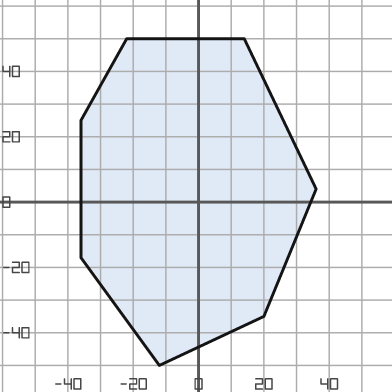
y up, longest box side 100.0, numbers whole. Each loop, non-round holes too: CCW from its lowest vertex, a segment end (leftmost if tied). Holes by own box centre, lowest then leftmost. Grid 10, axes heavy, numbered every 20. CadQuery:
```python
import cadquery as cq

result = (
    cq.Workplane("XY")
    .moveTo(-12.0, -50.0)
    .lineTo(20.0, -35.0)
    .lineTo(36.0, 4.0)
    .lineTo(14.0, 50.0)
    .lineTo(-22.0, 50.0)
    .lineTo(-36.0, 25.0)
    .lineTo(-36.0, -17.0)
    .close()
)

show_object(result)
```